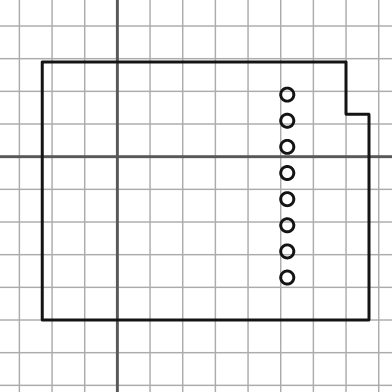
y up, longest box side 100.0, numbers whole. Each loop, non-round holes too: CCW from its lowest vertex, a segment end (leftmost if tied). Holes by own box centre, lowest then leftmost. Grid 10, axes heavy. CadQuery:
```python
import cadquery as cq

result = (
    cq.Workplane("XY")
    .moveTo(-23.0, -50.0)
    .lineTo(77.0, -50.0)
    .lineTo(77.0, 13.0)
    .lineTo(70.0, 13.0)
    .lineTo(70.0, 29.0)
    .lineTo(-23.0, 29.0)
    .close()
    .moveTo(52.0, -37.0)
    .circle(2.0)
    .moveTo(52.0, -29.0)
    .circle(2.0)
    .moveTo(52.0, -21.0)
    .circle(2.0)
    .moveTo(52.0, -13.0)
    .circle(2.0)
    .moveTo(52.0, -5.0)
    .circle(2.0)
    .moveTo(52.0, 3.0)
    .circle(2.0)
    .moveTo(52.0, 11.0)
    .circle(2.0)
    .moveTo(52.0, 19.0)
    .circle(2.0)
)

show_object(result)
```